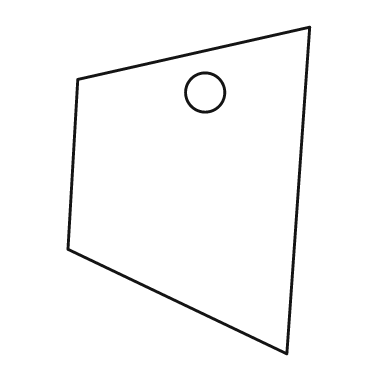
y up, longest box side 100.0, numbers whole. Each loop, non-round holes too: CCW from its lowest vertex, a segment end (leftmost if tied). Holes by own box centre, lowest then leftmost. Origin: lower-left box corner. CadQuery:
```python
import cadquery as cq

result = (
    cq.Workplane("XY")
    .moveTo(67.0, 0.0)
    .lineTo(74.0, 100.0)
    .lineTo(3.0, 84.0)
    .lineTo(0.0, 32.0)
    .close()
    .moveTo(42.0, 80.0)
    .circle(6.0)
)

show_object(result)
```